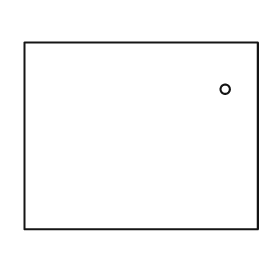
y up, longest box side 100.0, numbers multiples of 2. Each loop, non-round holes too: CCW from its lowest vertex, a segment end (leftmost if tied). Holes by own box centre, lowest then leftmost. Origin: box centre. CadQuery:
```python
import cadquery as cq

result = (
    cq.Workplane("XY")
    .moveTo(-50.0, -40.0)
    .lineTo(50.0, -40.0)
    .lineTo(50.0, 40.0)
    .lineTo(-50.0, 40.0)
    .close()
    .moveTo(36.0, 20.0)
    .circle(2.0)
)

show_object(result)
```